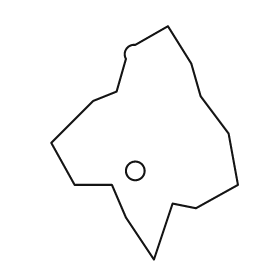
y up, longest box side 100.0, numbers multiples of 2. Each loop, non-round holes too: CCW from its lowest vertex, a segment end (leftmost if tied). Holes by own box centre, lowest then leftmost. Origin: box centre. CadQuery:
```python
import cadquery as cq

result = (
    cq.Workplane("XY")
    .moveTo(4.0, -50.0)
    .lineTo(12.0, -26.0)
    .lineTo(22.0, -28.0)
    .lineTo(40.0, -18.0)
    .lineTo(36.0, 4.0)
    .lineTo(24.0, 20.0)
    .lineTo(20.0, 34.0)
    .lineTo(10.0, 50.0)
    .lineTo(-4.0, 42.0)
    .threePointArc((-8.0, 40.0), (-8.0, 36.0))
    .lineTo(-12.0, 22.0)
    .lineTo(-22.0, 18.0)
    .lineTo(-40.0, 0.0)
    .lineTo(-30.0, -18.0)
    .lineTo(-14.0, -18.0)
    .lineTo(-8.0, -32.0)
    .close()
    .moveTo(-4.0, -12.0)
    .circle(4.0)
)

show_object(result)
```